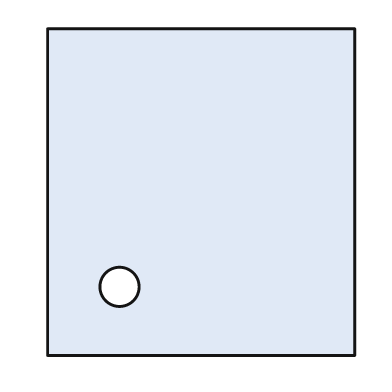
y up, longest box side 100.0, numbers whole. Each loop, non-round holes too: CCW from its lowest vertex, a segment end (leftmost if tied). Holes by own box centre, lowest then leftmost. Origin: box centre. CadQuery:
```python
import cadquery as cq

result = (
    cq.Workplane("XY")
    .moveTo(-47.0, -50.0)
    .lineTo(47.0, -50.0)
    .lineTo(47.0, 50.0)
    .lineTo(-47.0, 50.0)
    .close()
    .moveTo(-25.0, -29.0)
    .circle(6.0)
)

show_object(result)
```